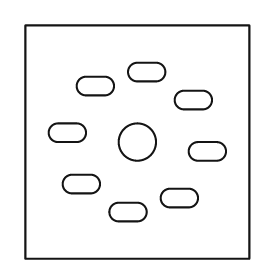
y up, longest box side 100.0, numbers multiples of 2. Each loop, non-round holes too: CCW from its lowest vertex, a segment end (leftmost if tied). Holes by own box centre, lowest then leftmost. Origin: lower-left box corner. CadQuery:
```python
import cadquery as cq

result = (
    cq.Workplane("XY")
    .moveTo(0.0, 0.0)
    .lineTo(96.0, 0.0)
    .lineTo(96.0, 100.0)
    .lineTo(0.0, 100.0)
    .close()
    .moveTo(40.0, 16.0)
    .lineTo(48.0, 16.0)
    .threePointArc((52.0, 20.0), (48.0, 24.0))
    .lineTo(40.0, 24.0)
    .threePointArc((36.0, 20.0), (40.0, 16.0))
    .close()
    .moveTo(62.0, 22.0)
    .lineTo(70.0, 22.0)
    .threePointArc((74.0, 26.0), (70.0, 30.0))
    .lineTo(62.0, 30.0)
    .threePointArc((58.0, 26.0), (62.0, 22.0))
    .close()
    .moveTo(20.0, 28.0)
    .lineTo(28.0, 28.0)
    .threePointArc((32.0, 32.0), (28.0, 36.0))
    .lineTo(20.0, 36.0)
    .threePointArc((16.0, 32.0), (20.0, 28.0))
    .close()
    .moveTo(74.0, 42.0)
    .lineTo(82.0, 42.0)
    .threePointArc((86.0, 46.0), (82.0, 50.0))
    .lineTo(74.0, 50.0)
    .threePointArc((70.0, 46.0), (74.0, 42.0))
    .close()
    .moveTo(48.0, 50.0)
    .circle(8.0)
    .moveTo(14.0, 50.0)
    .lineTo(22.0, 50.0)
    .threePointArc((26.0, 54.0), (22.0, 58.0))
    .lineTo(14.0, 58.0)
    .threePointArc((10.0, 54.0), (14.0, 50.0))
    .close()
    .moveTo(68.0, 64.0)
    .lineTo(76.0, 64.0)
    .threePointArc((80.0, 68.0), (76.0, 72.0))
    .lineTo(68.0, 72.0)
    .threePointArc((64.0, 68.0), (68.0, 64.0))
    .close()
    .moveTo(26.0, 70.0)
    .lineTo(34.0, 70.0)
    .threePointArc((38.0, 74.0), (34.0, 78.0))
    .lineTo(26.0, 78.0)
    .threePointArc((22.0, 74.0), (26.0, 70.0))
    .close()
    .moveTo(48.0, 76.0)
    .lineTo(56.0, 76.0)
    .threePointArc((60.0, 80.0), (56.0, 84.0))
    .lineTo(48.0, 84.0)
    .threePointArc((44.0, 80.0), (48.0, 76.0))
    .close()
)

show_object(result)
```